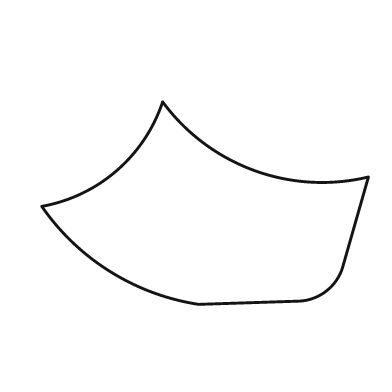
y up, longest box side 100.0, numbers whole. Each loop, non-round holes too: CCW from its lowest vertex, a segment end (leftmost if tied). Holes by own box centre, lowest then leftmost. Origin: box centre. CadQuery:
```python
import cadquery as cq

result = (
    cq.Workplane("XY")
    .moveTo(-2.0, -31.0)
    .lineTo(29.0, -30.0)
    .threePointArc((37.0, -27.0), (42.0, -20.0))
    .lineTo(50.0, 8.0)
    .threePointArc((15.0, 10.0), (-13.0, 31.0))
    .threePointArc((-27.0, 10.0), (-50.0, -1.0))
    .threePointArc((-29.0, -21.0), (-2.0, -31.0))
    .close()
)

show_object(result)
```